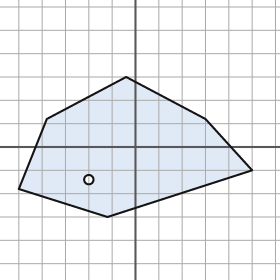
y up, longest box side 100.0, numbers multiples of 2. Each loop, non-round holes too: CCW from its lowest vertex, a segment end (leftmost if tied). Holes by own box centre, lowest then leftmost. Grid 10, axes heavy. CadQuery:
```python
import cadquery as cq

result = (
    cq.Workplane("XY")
    .moveTo(-12.0, -30.0)
    .lineTo(50.0, -10.0)
    .lineTo(30.0, 12.0)
    .lineTo(-4.0, 30.0)
    .lineTo(-38.0, 12.0)
    .lineTo(-50.0, -18.0)
    .close()
    .moveTo(-20.0, -14.0)
    .circle(2.0)
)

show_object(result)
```